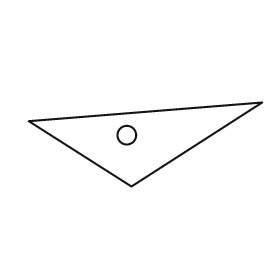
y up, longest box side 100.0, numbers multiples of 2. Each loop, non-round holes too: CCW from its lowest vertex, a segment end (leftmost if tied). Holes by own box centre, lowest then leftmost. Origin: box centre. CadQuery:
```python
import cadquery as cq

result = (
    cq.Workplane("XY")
    .moveTo(-6.0, -18.0)
    .lineTo(50.0, 18.0)
    .lineTo(-50.0, 10.0)
    .close()
    .moveTo(-8.0, 4.0)
    .circle(4.0)
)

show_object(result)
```